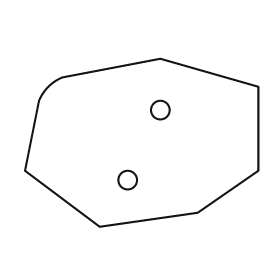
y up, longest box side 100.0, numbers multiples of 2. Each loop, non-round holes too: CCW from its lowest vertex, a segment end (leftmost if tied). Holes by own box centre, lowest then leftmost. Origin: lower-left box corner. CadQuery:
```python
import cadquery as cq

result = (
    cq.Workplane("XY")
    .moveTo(32.0, 0.0)
    .lineTo(74.0, 6.0)
    .lineTo(100.0, 24.0)
    .lineTo(100.0, 60.0)
    .lineTo(58.0, 72.0)
    .lineTo(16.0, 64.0)
    .threePointArc((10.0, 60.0), (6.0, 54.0))
    .lineTo(0.0, 24.0)
    .close()
    .moveTo(44.0, 20.0)
    .circle(4.0)
    .moveTo(58.0, 50.0)
    .circle(4.0)
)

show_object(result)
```